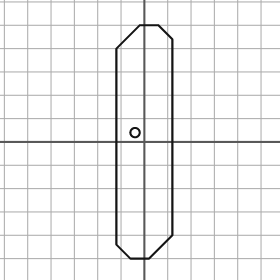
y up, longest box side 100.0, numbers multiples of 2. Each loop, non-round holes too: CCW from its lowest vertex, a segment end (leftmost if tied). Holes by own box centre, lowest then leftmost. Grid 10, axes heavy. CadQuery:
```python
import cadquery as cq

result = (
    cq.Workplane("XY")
    .moveTo(-6.0, -50.0)
    .lineTo(2.0, -50.0)
    .lineTo(12.0, -40.0)
    .lineTo(12.0, 44.0)
    .lineTo(6.0, 50.0)
    .lineTo(-2.0, 50.0)
    .lineTo(-12.0, 40.0)
    .lineTo(-12.0, -44.0)
    .close()
    .moveTo(-4.0, 4.0)
    .circle(2.0)
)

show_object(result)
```